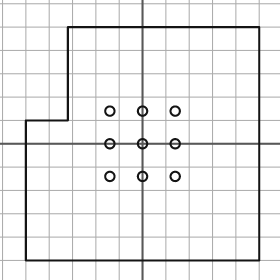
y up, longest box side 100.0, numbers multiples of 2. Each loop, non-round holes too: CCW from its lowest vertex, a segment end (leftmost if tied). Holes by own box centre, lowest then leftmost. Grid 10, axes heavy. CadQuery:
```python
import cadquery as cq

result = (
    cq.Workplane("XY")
    .moveTo(-50.0, -50.0)
    .lineTo(50.0, -50.0)
    .lineTo(50.0, 50.0)
    .lineTo(-32.0, 50.0)
    .lineTo(-32.0, 10.0)
    .lineTo(-50.0, 10.0)
    .close()
    .moveTo(-14.0, -14.0)
    .circle(2.0)
    .moveTo(0.0, -14.0)
    .circle(2.0)
    .moveTo(14.0, -14.0)
    .circle(2.0)
    .moveTo(-14.0, 0.0)
    .circle(2.0)
    .moveTo(0.0, 0.0)
    .circle(2.0)
    .moveTo(14.0, 0.0)
    .circle(2.0)
    .moveTo(-14.0, 14.0)
    .circle(2.0)
    .moveTo(0.0, 14.0)
    .circle(2.0)
    .moveTo(14.0, 14.0)
    .circle(2.0)
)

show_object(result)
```